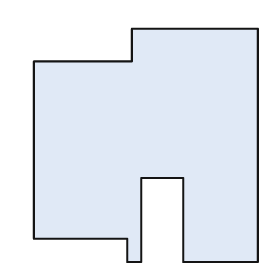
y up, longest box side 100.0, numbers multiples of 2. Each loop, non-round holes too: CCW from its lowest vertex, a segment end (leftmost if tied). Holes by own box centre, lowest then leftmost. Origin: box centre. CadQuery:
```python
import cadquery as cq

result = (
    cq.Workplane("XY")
    .moveTo(-8.0, -50.0)
    .lineTo(-2.0, -50.0)
    .lineTo(-2.0, -14.0)
    .lineTo(16.0, -14.0)
    .lineTo(16.0, -50.0)
    .lineTo(48.0, -50.0)
    .lineTo(48.0, 50.0)
    .lineTo(-6.0, 50.0)
    .lineTo(-6.0, 36.0)
    .lineTo(-48.0, 36.0)
    .lineTo(-48.0, -40.0)
    .lineTo(-8.0, -40.0)
    .close()
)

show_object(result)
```